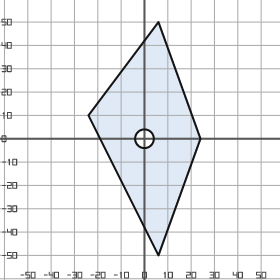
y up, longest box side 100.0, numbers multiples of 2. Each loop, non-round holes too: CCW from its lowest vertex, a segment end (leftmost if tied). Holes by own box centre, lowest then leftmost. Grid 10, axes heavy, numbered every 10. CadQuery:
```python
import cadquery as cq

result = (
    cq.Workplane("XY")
    .moveTo(6.0, -50.0)
    .lineTo(24.0, 0.0)
    .lineTo(6.0, 50.0)
    .lineTo(-24.0, 10.0)
    .close()
    .moveTo(0.0, 0.0)
    .circle(4.0)
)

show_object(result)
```